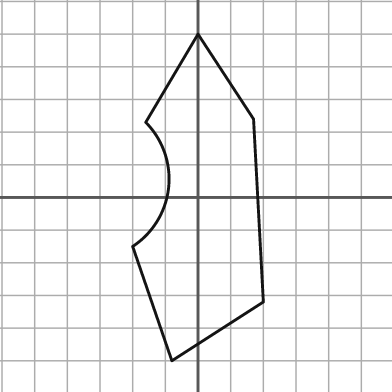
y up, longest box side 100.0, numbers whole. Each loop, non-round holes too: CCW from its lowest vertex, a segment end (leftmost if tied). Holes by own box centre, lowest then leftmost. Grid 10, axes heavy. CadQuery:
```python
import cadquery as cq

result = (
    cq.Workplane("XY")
    .moveTo(-8.0, -50.0)
    .lineTo(20.0, -32.0)
    .lineTo(17.0, 24.0)
    .lineTo(0.0, 50.0)
    .lineTo(-16.0, 23.0)
    .threePointArc((-9.0, 3.0), (-20.0, -15.0))
    .close()
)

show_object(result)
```